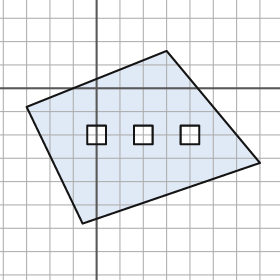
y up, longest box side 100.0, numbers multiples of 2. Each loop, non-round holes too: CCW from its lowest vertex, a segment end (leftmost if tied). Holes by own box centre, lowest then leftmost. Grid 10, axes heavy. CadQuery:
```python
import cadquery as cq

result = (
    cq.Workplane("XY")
    .moveTo(-6.0, -58.0)
    .lineTo(70.0, -32.0)
    .lineTo(30.0, 16.0)
    .lineTo(-30.0, -8.0)
    .close()
    .moveTo(-4.0, -24.0)
    .lineTo(4.0, -24.0)
    .lineTo(4.0, -16.0)
    .lineTo(-4.0, -16.0)
    .close()
    .moveTo(16.0, -24.0)
    .lineTo(24.0, -24.0)
    .lineTo(24.0, -16.0)
    .lineTo(16.0, -16.0)
    .close()
    .moveTo(36.0, -24.0)
    .lineTo(44.0, -24.0)
    .lineTo(44.0, -16.0)
    .lineTo(36.0, -16.0)
    .close()
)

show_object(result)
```